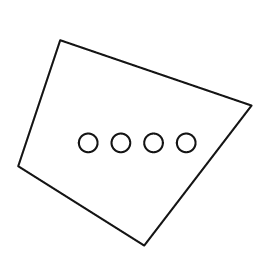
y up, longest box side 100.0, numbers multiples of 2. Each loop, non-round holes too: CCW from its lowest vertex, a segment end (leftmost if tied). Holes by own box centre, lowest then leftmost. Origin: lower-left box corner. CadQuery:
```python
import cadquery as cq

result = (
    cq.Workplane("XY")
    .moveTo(54.0, 0.0)
    .lineTo(100.0, 60.0)
    .lineTo(18.0, 88.0)
    .lineTo(0.0, 34.0)
    .close()
    .moveTo(30.0, 44.0)
    .circle(4.0)
    .moveTo(44.0, 44.0)
    .circle(4.0)
    .moveTo(58.0, 44.0)
    .circle(4.0)
    .moveTo(72.0, 44.0)
    .circle(4.0)
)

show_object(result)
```